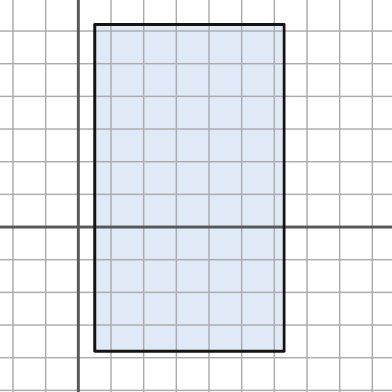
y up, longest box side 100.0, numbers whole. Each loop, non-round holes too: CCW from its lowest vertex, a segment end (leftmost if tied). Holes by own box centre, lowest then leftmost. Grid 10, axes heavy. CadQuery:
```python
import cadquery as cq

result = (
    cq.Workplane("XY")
    .moveTo(5.0, -38.0)
    .lineTo(63.0, -38.0)
    .lineTo(63.0, 62.0)
    .lineTo(5.0, 62.0)
    .close()
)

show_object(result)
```